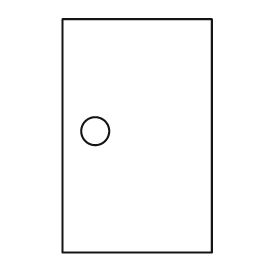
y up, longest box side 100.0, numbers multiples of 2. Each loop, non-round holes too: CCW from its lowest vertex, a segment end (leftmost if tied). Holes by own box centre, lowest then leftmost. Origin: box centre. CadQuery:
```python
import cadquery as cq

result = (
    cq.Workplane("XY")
    .moveTo(-32.0, -50.0)
    .lineTo(32.0, -50.0)
    .lineTo(32.0, 50.0)
    .lineTo(-32.0, 50.0)
    .close()
    .moveTo(-18.0, 2.0)
    .circle(6.0)
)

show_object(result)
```